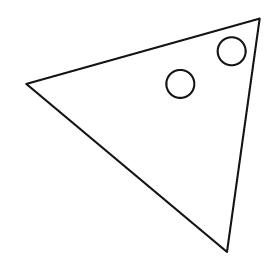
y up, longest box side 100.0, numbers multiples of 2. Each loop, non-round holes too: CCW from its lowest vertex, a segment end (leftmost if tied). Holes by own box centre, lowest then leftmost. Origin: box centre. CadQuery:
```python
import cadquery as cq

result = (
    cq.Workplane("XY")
    .moveTo(36.0, -50.0)
    .lineTo(50.0, 50.0)
    .lineTo(-50.0, 22.0)
    .close()
    .moveTo(16.0, 22.0)
    .circle(6.0)
    .moveTo(38.0, 36.0)
    .circle(6.0)
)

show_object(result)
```